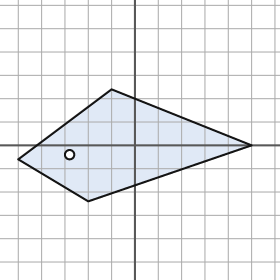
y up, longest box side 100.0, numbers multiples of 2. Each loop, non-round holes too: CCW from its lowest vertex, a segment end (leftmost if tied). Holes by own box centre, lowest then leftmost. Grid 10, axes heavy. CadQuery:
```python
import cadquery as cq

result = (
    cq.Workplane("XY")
    .moveTo(-20.0, -24.0)
    .lineTo(50.0, 0.0)
    .lineTo(-10.0, 24.0)
    .lineTo(-50.0, -6.0)
    .close()
    .moveTo(-28.0, -4.0)
    .circle(2.0)
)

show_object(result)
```